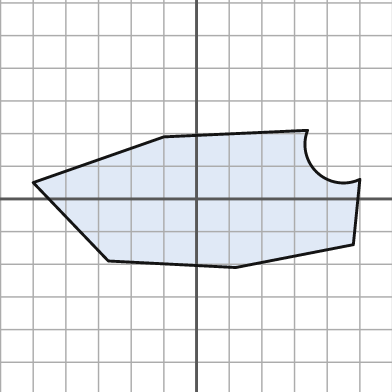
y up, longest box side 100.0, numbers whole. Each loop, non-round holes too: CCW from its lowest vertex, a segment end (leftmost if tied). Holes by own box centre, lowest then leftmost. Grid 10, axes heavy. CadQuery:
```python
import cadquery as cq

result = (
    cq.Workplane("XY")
    .moveTo(12.0, -21.0)
    .lineTo(48.0, -14.0)
    .lineTo(50.0, 6.0)
    .threePointArc((37.0, 8.0), (34.0, 21.0))
    .lineTo(-10.0, 19.0)
    .lineTo(-50.0, 5.0)
    .lineTo(-27.0, -19.0)
    .close()
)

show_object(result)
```